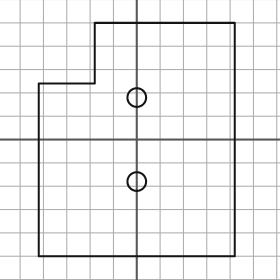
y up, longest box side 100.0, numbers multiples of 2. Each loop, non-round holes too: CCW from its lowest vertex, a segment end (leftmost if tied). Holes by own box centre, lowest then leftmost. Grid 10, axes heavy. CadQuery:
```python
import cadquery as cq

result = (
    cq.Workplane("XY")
    .moveTo(-42.0, -50.0)
    .lineTo(42.0, -50.0)
    .lineTo(42.0, 50.0)
    .lineTo(-18.0, 50.0)
    .lineTo(-18.0, 24.0)
    .lineTo(-42.0, 24.0)
    .close()
    .moveTo(0.0, -18.0)
    .circle(4.0)
    .moveTo(0.0, 18.0)
    .circle(4.0)
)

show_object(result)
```